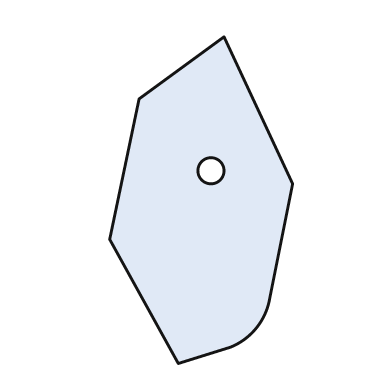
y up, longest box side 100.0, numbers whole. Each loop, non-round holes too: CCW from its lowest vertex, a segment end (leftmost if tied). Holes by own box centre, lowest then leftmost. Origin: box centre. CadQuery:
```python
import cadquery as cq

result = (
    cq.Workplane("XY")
    .moveTo(-7.0, -50.0)
    .lineTo(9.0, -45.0)
    .threePointArc((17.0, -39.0), (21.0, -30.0))
    .lineTo(28.0, 5.0)
    .lineTo(7.0, 50.0)
    .lineTo(-19.0, 31.0)
    .lineTo(-28.0, -12.0)
    .close()
    .moveTo(3.0, 9.0)
    .circle(4.0)
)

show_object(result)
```